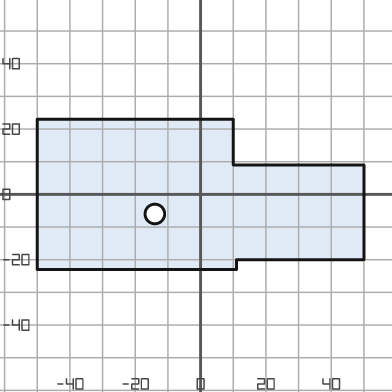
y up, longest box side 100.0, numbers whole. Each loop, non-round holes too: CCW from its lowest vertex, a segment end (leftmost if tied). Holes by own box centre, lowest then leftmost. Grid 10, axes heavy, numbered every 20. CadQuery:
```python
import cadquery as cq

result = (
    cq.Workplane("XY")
    .moveTo(-50.0, -23.0)
    .lineTo(11.0, -23.0)
    .lineTo(11.0, -20.0)
    .lineTo(50.0, -20.0)
    .lineTo(50.0, 9.0)
    .lineTo(10.0, 9.0)
    .lineTo(10.0, 23.0)
    .lineTo(-50.0, 23.0)
    .close()
    .moveTo(-14.0, -6.0)
    .circle(3.0)
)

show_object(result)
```